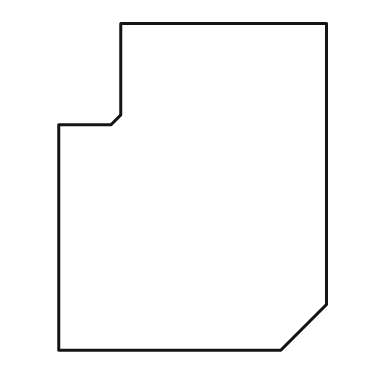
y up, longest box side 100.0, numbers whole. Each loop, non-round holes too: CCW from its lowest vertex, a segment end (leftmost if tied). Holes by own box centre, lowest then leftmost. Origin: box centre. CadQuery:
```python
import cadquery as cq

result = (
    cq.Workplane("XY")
    .moveTo(-41.0, -50.0)
    .lineTo(27.0, -50.0)
    .lineTo(41.0, -36.0)
    .lineTo(41.0, 50.0)
    .lineTo(-22.0, 50.0)
    .lineTo(-22.0, 22.0)
    .lineTo(-25.0, 19.0)
    .lineTo(-41.0, 19.0)
    .close()
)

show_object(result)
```